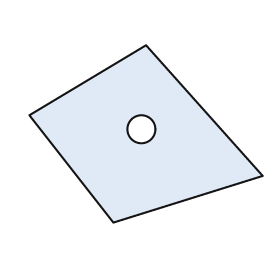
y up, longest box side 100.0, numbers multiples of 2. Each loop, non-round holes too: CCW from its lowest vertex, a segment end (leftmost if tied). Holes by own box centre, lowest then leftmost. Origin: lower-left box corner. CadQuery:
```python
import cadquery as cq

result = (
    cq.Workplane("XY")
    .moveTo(36.0, 0.0)
    .lineTo(100.0, 20.0)
    .lineTo(50.0, 76.0)
    .lineTo(0.0, 46.0)
    .close()
    .moveTo(48.0, 40.0)
    .circle(6.0)
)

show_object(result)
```